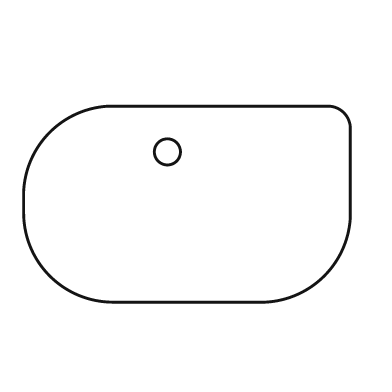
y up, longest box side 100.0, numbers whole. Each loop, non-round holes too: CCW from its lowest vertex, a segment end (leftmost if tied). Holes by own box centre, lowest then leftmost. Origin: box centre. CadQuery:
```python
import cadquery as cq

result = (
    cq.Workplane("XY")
    .moveTo(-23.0, -30.0)
    .lineTo(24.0, -30.0)
    .threePointArc((42.0, -22.0), (50.0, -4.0))
    .lineTo(50.0, 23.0)
    .threePointArc((48.0, 28.0), (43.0, 30.0))
    .lineTo(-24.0, 30.0)
    .threePointArc((-42.0, 22.0), (-50.0, 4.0))
    .lineTo(-50.0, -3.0)
    .threePointArc((-42.0, -22.0), (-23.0, -30.0))
    .close()
    .moveTo(-6.0, 16.0)
    .circle(4.0)
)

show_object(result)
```